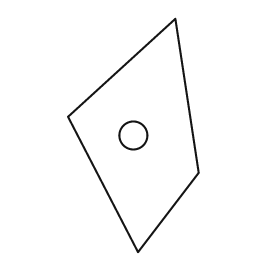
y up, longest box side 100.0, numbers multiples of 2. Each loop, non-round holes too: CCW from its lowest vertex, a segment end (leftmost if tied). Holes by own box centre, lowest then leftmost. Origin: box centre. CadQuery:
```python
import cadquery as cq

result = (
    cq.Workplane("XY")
    .moveTo(2.0, -50.0)
    .lineTo(28.0, -16.0)
    .lineTo(18.0, 50.0)
    .lineTo(-28.0, 8.0)
    .close()
    .moveTo(0.0, 0.0)
    .circle(6.0)
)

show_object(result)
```